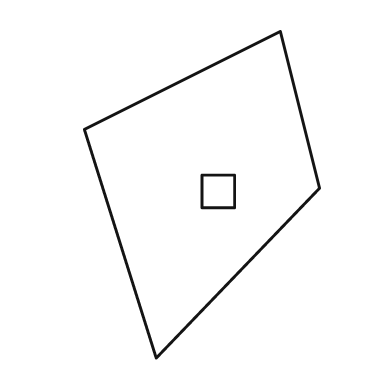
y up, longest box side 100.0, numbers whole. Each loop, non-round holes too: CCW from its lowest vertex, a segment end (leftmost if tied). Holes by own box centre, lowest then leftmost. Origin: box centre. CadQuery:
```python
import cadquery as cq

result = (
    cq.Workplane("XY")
    .moveTo(-14.0, -50.0)
    .lineTo(36.0, 2.0)
    .lineTo(24.0, 50.0)
    .lineTo(-36.0, 20.0)
    .close()
    .moveTo(0.0, -4.0)
    .lineTo(10.0, -4.0)
    .lineTo(10.0, 6.0)
    .lineTo(0.0, 6.0)
    .close()
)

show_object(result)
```